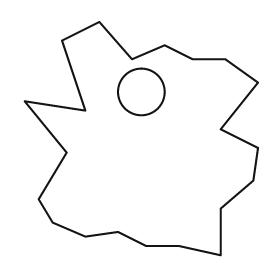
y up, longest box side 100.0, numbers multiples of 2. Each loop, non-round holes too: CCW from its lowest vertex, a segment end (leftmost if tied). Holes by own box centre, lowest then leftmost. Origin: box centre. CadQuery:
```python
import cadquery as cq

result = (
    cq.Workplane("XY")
    .moveTo(34.0, -50.0)
    .lineTo(34.0, -30.0)
    .lineTo(48.0, -18.0)
    .lineTo(50.0, -4.0)
    .lineTo(34.0, 4.0)
    .lineTo(50.0, 24.0)
    .lineTo(36.0, 34.0)
    .lineTo(22.0, 34.0)
    .lineTo(10.0, 40.0)
    .lineTo(-4.0, 34.0)
    .lineTo(-18.0, 50.0)
    .lineTo(-34.0, 42.0)
    .lineTo(-24.0, 12.0)
    .lineTo(-50.0, 16.0)
    .lineTo(-32.0, -6.0)
    .lineTo(-44.0, -26.0)
    .lineTo(-38.0, -36.0)
    .lineTo(-24.0, -42.0)
    .lineTo(-10.0, -40.0)
    .lineTo(2.0, -46.0)
    .lineTo(16.0, -46.0)
    .close()
    .moveTo(0.0, 20.0)
    .circle(10.0)
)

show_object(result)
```